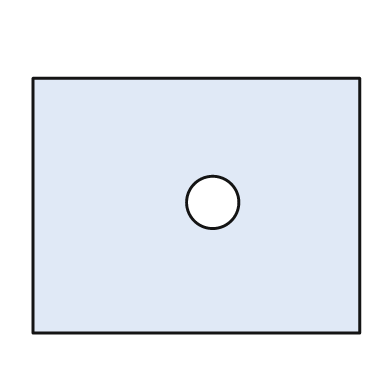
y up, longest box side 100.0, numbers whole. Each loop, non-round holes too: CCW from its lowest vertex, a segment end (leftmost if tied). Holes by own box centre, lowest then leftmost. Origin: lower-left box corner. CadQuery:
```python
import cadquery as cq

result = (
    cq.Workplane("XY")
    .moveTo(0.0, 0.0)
    .lineTo(100.0, 0.0)
    .lineTo(100.0, 78.0)
    .lineTo(0.0, 78.0)
    .close()
    .moveTo(55.0, 40.0)
    .circle(8.0)
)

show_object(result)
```